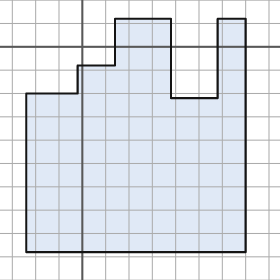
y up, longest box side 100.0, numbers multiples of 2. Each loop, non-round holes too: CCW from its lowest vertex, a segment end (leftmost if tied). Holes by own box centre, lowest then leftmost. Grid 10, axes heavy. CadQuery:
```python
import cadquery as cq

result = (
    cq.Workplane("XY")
    .moveTo(-24.0, -88.0)
    .lineTo(70.0, -88.0)
    .lineTo(70.0, 12.0)
    .lineTo(58.0, 12.0)
    .lineTo(58.0, -22.0)
    .lineTo(38.0, -22.0)
    .lineTo(38.0, 12.0)
    .lineTo(14.0, 12.0)
    .lineTo(14.0, -8.0)
    .lineTo(-2.0, -8.0)
    .lineTo(-2.0, -20.0)
    .lineTo(-24.0, -20.0)
    .close()
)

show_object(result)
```